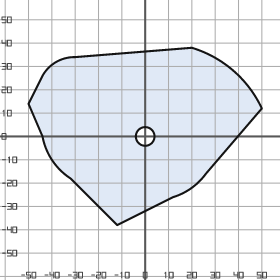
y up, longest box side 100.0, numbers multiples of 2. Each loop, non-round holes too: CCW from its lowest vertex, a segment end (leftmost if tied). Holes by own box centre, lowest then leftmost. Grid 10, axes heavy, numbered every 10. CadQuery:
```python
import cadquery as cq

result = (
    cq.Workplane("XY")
    .moveTo(-12.0, -38.0)
    .lineTo(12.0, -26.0)
    .threePointArc((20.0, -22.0), (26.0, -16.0))
    .lineTo(50.0, 12.0)
    .threePointArc((38.0, 28.0), (20.0, 38.0))
    .lineTo(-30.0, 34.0)
    .threePointArc((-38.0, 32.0), (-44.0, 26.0))
    .lineTo(-50.0, 14.0)
    .lineTo(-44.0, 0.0)
    .threePointArc((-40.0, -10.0), (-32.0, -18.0))
    .close()
    .moveTo(0.0, 0.0)
    .circle(4.0)
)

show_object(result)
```